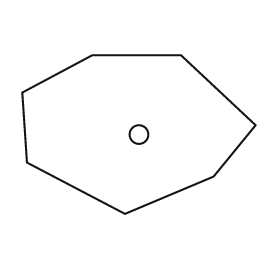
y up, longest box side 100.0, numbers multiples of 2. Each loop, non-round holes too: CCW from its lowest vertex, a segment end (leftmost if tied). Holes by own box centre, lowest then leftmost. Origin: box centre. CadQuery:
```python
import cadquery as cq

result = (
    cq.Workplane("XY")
    .moveTo(-6.0, -34.0)
    .lineTo(32.0, -18.0)
    .lineTo(50.0, 4.0)
    .lineTo(18.0, 34.0)
    .lineTo(-20.0, 34.0)
    .lineTo(-50.0, 18.0)
    .lineTo(-48.0, -12.0)
    .close()
    .moveTo(0.0, 0.0)
    .circle(4.0)
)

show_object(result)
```